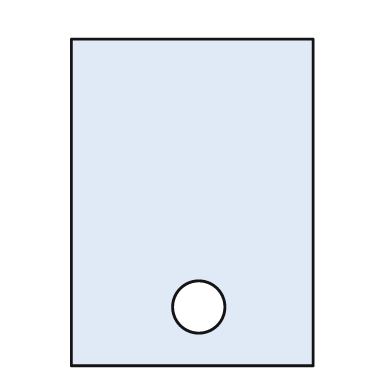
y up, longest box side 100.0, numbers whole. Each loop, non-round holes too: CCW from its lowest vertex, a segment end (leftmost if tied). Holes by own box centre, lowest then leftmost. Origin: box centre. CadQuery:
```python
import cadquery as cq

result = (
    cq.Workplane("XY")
    .moveTo(-37.0, -50.0)
    .lineTo(37.0, -50.0)
    .lineTo(37.0, 50.0)
    .lineTo(-37.0, 50.0)
    .close()
    .moveTo(2.0, -32.0)
    .circle(8.0)
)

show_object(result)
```